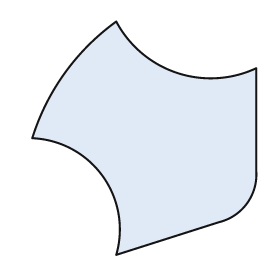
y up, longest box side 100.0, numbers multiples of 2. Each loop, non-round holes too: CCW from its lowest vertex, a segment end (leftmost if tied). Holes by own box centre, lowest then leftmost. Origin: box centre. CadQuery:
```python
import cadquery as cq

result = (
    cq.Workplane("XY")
    .moveTo(-12.0, -50.0)
    .lineTo(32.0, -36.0)
    .threePointArc((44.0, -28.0), (48.0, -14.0))
    .lineTo(48.0, 30.0)
    .threePointArc((14.0, 28.0), (-12.0, 50.0))
    .threePointArc((-34.0, 28.0), (-48.0, 0.0))
    .threePointArc((-18.0, -16.0), (-12.0, -50.0))
    .close()
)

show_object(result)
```